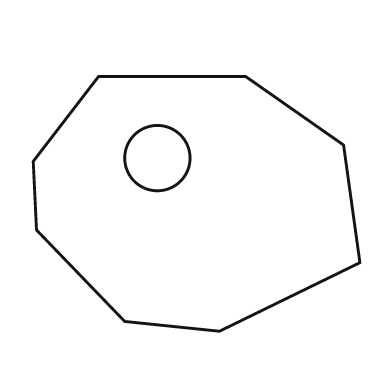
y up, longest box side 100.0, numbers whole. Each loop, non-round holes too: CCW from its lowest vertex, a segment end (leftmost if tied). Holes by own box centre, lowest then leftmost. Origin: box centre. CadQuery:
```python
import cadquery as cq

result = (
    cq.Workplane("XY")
    .moveTo(7.0, -39.0)
    .lineTo(50.0, -18.0)
    .lineTo(45.0, 18.0)
    .lineTo(15.0, 39.0)
    .lineTo(-30.0, 39.0)
    .lineTo(-50.0, 13.0)
    .lineTo(-49.0, -8.0)
    .lineTo(-22.0, -36.0)
    .close()
    .moveTo(-12.0, 14.0)
    .circle(10.0)
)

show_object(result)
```